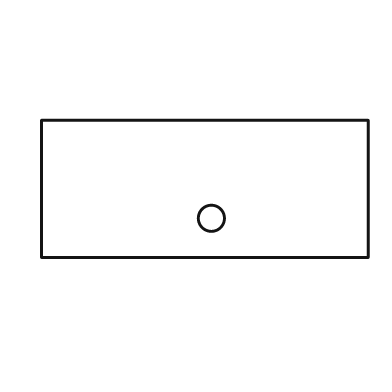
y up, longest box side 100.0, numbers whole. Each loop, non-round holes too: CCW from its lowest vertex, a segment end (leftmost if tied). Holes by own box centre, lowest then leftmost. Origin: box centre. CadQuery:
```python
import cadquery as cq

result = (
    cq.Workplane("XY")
    .moveTo(-50.0, -21.0)
    .lineTo(50.0, -21.0)
    .lineTo(50.0, 21.0)
    .lineTo(-50.0, 21.0)
    .close()
    .moveTo(2.0, -9.0)
    .circle(4.0)
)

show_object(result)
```